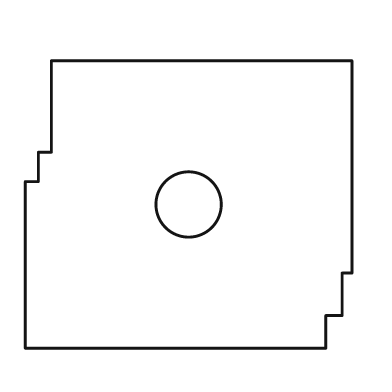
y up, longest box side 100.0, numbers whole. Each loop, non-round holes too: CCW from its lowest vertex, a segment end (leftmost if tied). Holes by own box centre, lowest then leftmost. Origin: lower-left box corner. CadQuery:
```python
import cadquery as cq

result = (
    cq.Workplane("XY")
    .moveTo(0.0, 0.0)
    .lineTo(92.0, 0.0)
    .lineTo(92.0, 10.0)
    .lineTo(97.0, 10.0)
    .lineTo(97.0, 23.0)
    .lineTo(100.0, 23.0)
    .lineTo(100.0, 88.0)
    .lineTo(8.0, 88.0)
    .lineTo(8.0, 60.0)
    .lineTo(4.0, 60.0)
    .lineTo(4.0, 51.0)
    .lineTo(0.0, 51.0)
    .close()
    .moveTo(50.0, 44.0)
    .circle(10.0)
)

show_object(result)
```